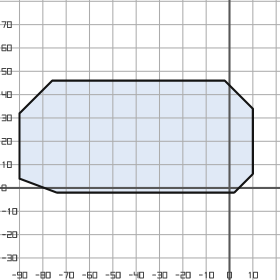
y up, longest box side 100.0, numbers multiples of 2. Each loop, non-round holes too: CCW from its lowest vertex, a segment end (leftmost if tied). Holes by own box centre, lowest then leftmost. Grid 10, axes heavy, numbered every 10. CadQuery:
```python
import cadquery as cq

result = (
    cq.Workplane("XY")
    .moveTo(-74.0, -2.0)
    .lineTo(2.0, -2.0)
    .lineTo(10.0, 6.0)
    .lineTo(10.0, 34.0)
    .lineTo(-2.0, 46.0)
    .lineTo(-76.0, 46.0)
    .lineTo(-90.0, 32.0)
    .lineTo(-90.0, 4.0)
    .close()
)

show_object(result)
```